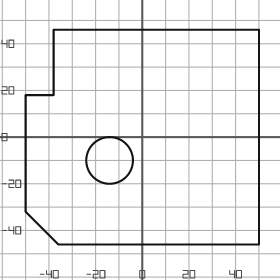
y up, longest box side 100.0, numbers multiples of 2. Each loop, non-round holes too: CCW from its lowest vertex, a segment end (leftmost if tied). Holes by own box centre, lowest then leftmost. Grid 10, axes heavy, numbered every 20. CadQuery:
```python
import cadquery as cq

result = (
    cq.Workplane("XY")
    .moveTo(-36.0, -46.0)
    .lineTo(50.0, -46.0)
    .lineTo(50.0, 46.0)
    .lineTo(-38.0, 46.0)
    .lineTo(-38.0, 18.0)
    .lineTo(-50.0, 18.0)
    .lineTo(-50.0, -32.0)
    .close()
    .moveTo(-14.0, -10.0)
    .circle(10.0)
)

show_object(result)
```